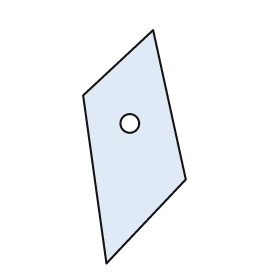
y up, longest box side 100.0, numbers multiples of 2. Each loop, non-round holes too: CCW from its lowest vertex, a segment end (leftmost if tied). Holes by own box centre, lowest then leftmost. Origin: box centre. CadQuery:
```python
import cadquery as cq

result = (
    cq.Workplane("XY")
    .moveTo(-12.0, -50.0)
    .lineTo(22.0, -14.0)
    .lineTo(8.0, 50.0)
    .lineTo(-22.0, 22.0)
    .close()
    .moveTo(-2.0, 10.0)
    .circle(4.0)
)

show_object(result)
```